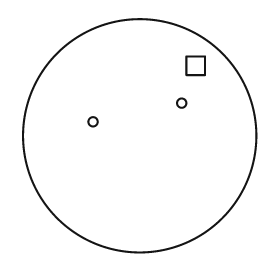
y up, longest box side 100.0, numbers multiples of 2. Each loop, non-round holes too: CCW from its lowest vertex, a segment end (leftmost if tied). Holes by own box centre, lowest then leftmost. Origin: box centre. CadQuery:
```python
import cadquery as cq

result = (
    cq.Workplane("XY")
    .moveTo(0.0, 0.0)
    .circle(50.0)
    .moveTo(-20.0, 6.0)
    .circle(2.0)
    .moveTo(18.0, 14.0)
    .circle(2.0)
    .moveTo(20.0, 26.0)
    .lineTo(28.0, 26.0)
    .lineTo(28.0, 34.0)
    .lineTo(20.0, 34.0)
    .close()
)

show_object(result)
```